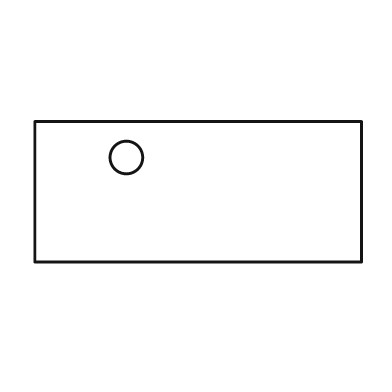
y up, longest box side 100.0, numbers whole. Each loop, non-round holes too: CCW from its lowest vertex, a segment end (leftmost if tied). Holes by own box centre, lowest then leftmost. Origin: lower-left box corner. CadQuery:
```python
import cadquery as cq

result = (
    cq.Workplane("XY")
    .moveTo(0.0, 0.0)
    .lineTo(100.0, 0.0)
    .lineTo(100.0, 43.0)
    .lineTo(0.0, 43.0)
    .close()
    .moveTo(28.0, 32.0)
    .circle(5.0)
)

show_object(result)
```